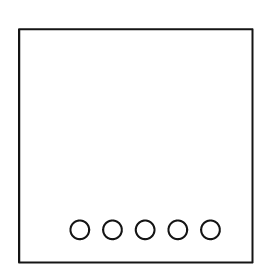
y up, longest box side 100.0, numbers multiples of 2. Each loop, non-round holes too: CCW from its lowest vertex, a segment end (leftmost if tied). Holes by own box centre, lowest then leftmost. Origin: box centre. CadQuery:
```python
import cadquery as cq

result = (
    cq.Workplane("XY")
    .moveTo(-50.0, -50.0)
    .lineTo(50.0, -50.0)
    .lineTo(50.0, 50.0)
    .lineTo(-50.0, 50.0)
    .close()
    .moveTo(-24.0, -36.0)
    .circle(4.0)
    .moveTo(-10.0, -36.0)
    .circle(4.0)
    .moveTo(4.0, -36.0)
    .circle(4.0)
    .moveTo(18.0, -36.0)
    .circle(4.0)
    .moveTo(32.0, -36.0)
    .circle(4.0)
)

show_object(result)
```